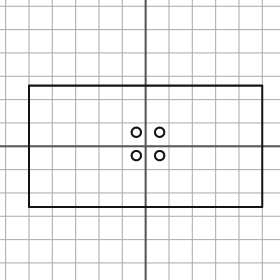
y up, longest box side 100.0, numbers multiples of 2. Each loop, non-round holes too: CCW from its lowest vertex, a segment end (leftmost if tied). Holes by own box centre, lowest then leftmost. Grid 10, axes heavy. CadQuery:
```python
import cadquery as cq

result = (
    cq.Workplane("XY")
    .moveTo(-50.0, -26.0)
    .lineTo(50.0, -26.0)
    .lineTo(50.0, 26.0)
    .lineTo(-50.0, 26.0)
    .close()
    .moveTo(-4.0, -4.0)
    .circle(2.0)
    .moveTo(6.0, -4.0)
    .circle(2.0)
    .moveTo(-4.0, 6.0)
    .circle(2.0)
    .moveTo(6.0, 6.0)
    .circle(2.0)
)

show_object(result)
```